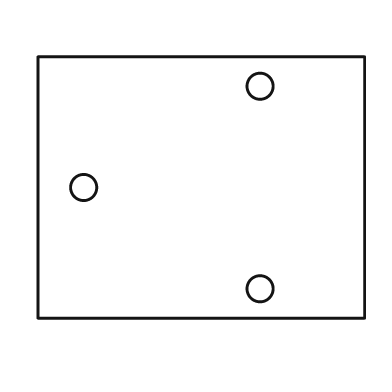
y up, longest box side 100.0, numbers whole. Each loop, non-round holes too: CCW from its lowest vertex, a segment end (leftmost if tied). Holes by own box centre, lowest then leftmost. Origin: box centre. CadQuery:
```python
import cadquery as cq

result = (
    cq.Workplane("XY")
    .moveTo(-50.0, -40.0)
    .lineTo(50.0, -40.0)
    .lineTo(50.0, 40.0)
    .lineTo(-50.0, 40.0)
    .close()
    .moveTo(18.0, -31.0)
    .circle(4.0)
    .moveTo(-36.0, 0.0)
    .circle(4.0)
    .moveTo(18.0, 31.0)
    .circle(4.0)
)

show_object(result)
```